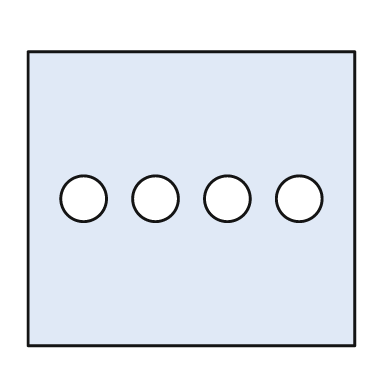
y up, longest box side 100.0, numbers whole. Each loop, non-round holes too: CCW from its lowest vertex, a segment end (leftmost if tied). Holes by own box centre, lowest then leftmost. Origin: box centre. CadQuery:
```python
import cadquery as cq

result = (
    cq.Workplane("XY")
    .moveTo(-50.0, -45.0)
    .lineTo(50.0, -45.0)
    .lineTo(50.0, 45.0)
    .lineTo(-50.0, 45.0)
    .close()
    .moveTo(-33.0, 0.0)
    .circle(7.0)
    .moveTo(-11.0, 0.0)
    .circle(7.0)
    .moveTo(11.0, 0.0)
    .circle(7.0)
    .moveTo(33.0, 0.0)
    .circle(7.0)
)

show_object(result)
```